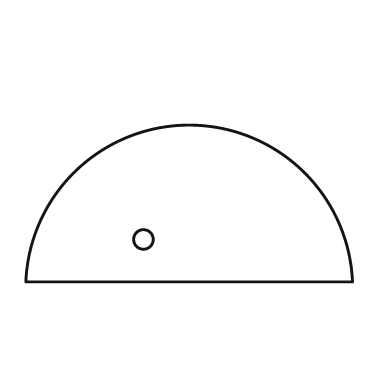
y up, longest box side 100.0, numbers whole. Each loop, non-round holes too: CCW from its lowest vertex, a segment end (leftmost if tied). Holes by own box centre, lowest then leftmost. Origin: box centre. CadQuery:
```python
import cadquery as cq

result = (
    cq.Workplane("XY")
    .moveTo(-50.0, -24.0)
    .lineTo(50.0, -24.0)
    .threePointArc((0.0, 24.0), (-50.0, -24.0))
    .close()
    .moveTo(-14.0, -11.0)
    .circle(3.0)
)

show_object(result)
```